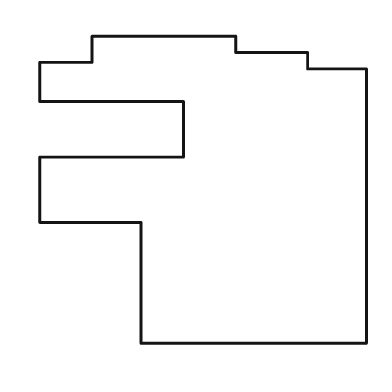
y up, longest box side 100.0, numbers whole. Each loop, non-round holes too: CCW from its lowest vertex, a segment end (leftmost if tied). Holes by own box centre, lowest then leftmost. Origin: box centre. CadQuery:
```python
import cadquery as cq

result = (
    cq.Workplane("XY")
    .moveTo(-19.0, -47.0)
    .lineTo(50.0, -47.0)
    .lineTo(50.0, 37.0)
    .lineTo(32.0, 37.0)
    .lineTo(32.0, 42.0)
    .lineTo(10.0, 42.0)
    .lineTo(10.0, 47.0)
    .lineTo(-34.0, 47.0)
    .lineTo(-34.0, 39.0)
    .lineTo(-50.0, 39.0)
    .lineTo(-50.0, 27.0)
    .lineTo(-6.0, 27.0)
    .lineTo(-6.0, 10.0)
    .lineTo(-50.0, 10.0)
    .lineTo(-50.0, -10.0)
    .lineTo(-19.0, -10.0)
    .close()
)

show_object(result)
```